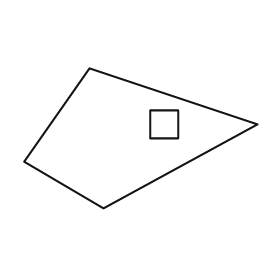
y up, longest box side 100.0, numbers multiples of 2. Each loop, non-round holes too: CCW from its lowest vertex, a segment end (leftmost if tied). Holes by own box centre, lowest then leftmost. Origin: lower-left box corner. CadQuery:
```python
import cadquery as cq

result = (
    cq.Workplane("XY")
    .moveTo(34.0, 0.0)
    .lineTo(100.0, 36.0)
    .lineTo(28.0, 60.0)
    .lineTo(0.0, 20.0)
    .close()
    .moveTo(54.0, 30.0)
    .lineTo(66.0, 30.0)
    .lineTo(66.0, 42.0)
    .lineTo(54.0, 42.0)
    .close()
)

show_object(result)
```